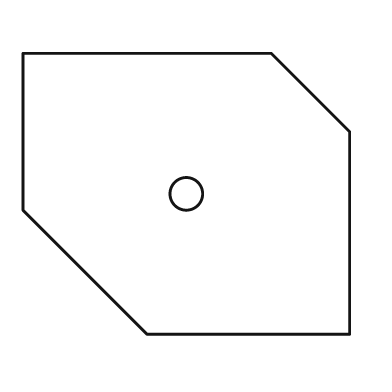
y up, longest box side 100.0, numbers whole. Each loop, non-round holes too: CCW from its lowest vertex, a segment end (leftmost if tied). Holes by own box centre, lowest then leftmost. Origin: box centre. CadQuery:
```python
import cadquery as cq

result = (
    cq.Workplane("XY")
    .moveTo(-12.0, -43.0)
    .lineTo(50.0, -43.0)
    .lineTo(50.0, 19.0)
    .lineTo(26.0, 43.0)
    .lineTo(-50.0, 43.0)
    .lineTo(-50.0, -5.0)
    .close()
    .moveTo(0.0, 0.0)
    .circle(5.0)
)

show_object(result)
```